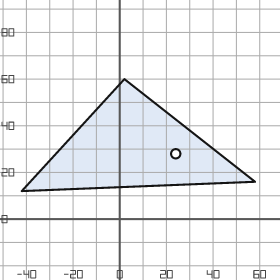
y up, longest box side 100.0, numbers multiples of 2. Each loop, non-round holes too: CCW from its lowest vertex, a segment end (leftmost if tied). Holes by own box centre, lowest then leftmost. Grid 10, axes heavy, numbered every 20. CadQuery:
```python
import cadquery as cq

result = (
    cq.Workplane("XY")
    .moveTo(-42.0, 12.0)
    .lineTo(58.0, 16.0)
    .lineTo(2.0, 60.0)
    .close()
    .moveTo(24.0, 28.0)
    .circle(2.0)
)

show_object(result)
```